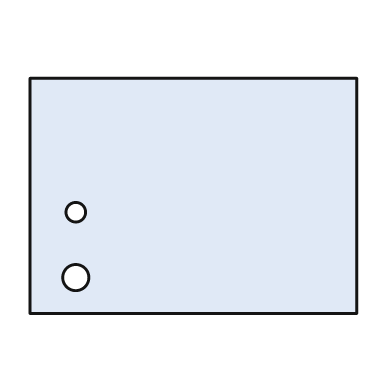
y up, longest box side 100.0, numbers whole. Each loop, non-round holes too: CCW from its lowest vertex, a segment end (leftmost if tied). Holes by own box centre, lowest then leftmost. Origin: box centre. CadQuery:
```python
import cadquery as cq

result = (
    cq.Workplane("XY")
    .moveTo(-50.0, -36.0)
    .lineTo(50.0, -36.0)
    .lineTo(50.0, 36.0)
    .lineTo(-50.0, 36.0)
    .close()
    .moveTo(-36.0, -25.0)
    .circle(4.0)
    .moveTo(-36.0, -5.0)
    .circle(3.0)
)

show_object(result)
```